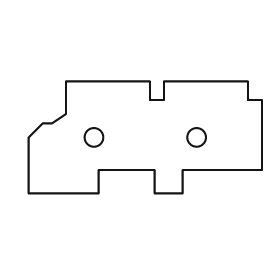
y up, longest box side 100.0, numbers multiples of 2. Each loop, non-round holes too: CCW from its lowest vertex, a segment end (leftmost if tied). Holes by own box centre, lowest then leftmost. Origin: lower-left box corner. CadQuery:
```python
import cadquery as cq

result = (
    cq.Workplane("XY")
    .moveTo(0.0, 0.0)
    .lineTo(30.0, 0.0)
    .lineTo(30.0, 10.0)
    .lineTo(54.0, 10.0)
    .lineTo(54.0, 0.0)
    .lineTo(66.0, 0.0)
    .lineTo(66.0, 10.0)
    .lineTo(100.0, 10.0)
    .lineTo(100.0, 40.0)
    .lineTo(94.0, 40.0)
    .lineTo(94.0, 48.0)
    .lineTo(58.0, 48.0)
    .lineTo(58.0, 40.0)
    .lineTo(52.0, 40.0)
    .lineTo(52.0, 48.0)
    .lineTo(16.0, 48.0)
    .lineTo(16.0, 34.0)
    .lineTo(10.0, 30.0)
    .lineTo(6.0, 30.0)
    .lineTo(0.0, 24.0)
    .close()
    .moveTo(28.0, 24.0)
    .circle(4.0)
    .moveTo(72.0, 24.0)
    .circle(4.0)
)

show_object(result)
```